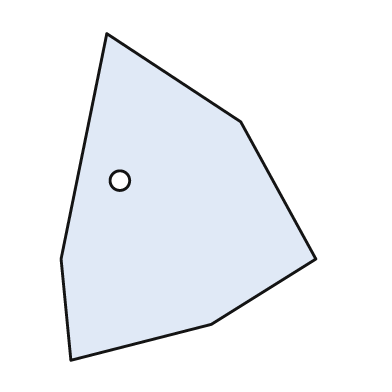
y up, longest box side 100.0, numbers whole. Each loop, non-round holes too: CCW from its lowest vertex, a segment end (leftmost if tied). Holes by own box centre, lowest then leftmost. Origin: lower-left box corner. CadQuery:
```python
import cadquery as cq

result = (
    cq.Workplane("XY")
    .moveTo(3.0, 0.0)
    .lineTo(46.0, 11.0)
    .lineTo(78.0, 31.0)
    .lineTo(55.0, 73.0)
    .lineTo(14.0, 100.0)
    .lineTo(0.0, 31.0)
    .close()
    .moveTo(18.0, 55.0)
    .circle(3.0)
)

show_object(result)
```